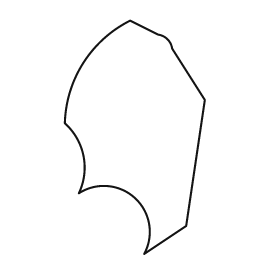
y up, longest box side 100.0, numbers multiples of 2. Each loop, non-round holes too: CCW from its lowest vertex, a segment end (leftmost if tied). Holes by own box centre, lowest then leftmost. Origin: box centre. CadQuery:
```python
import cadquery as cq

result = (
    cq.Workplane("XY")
    .moveTo(4.0, -50.0)
    .lineTo(22.0, -38.0)
    .lineTo(30.0, 16.0)
    .lineTo(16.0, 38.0)
    .threePointArc((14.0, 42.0), (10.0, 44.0))
    .lineTo(-2.0, 50.0)
    .threePointArc((-22.0, 32.0), (-30.0, 6.0))
    .threePointArc((-22.0, -8.0), (-24.0, -24.0))
    .threePointArc((0.0, -26.0), (4.0, -50.0))
    .close()
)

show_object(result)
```